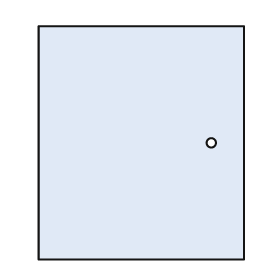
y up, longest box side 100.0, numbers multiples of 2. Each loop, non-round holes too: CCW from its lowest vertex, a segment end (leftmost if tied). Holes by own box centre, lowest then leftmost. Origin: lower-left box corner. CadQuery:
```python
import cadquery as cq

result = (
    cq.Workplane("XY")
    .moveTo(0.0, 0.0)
    .lineTo(88.0, 0.0)
    .lineTo(88.0, 100.0)
    .lineTo(0.0, 100.0)
    .close()
    .moveTo(74.0, 50.0)
    .circle(2.0)
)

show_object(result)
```